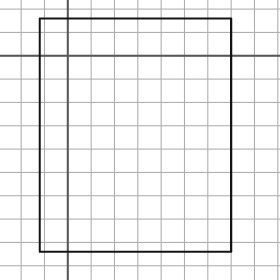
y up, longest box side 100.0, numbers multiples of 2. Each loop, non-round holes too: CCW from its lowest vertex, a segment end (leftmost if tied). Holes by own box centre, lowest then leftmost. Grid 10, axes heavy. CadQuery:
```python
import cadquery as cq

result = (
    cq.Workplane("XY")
    .moveTo(-12.0, -84.0)
    .lineTo(70.0, -84.0)
    .lineTo(70.0, 16.0)
    .lineTo(-12.0, 16.0)
    .close()
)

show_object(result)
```